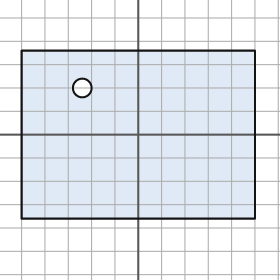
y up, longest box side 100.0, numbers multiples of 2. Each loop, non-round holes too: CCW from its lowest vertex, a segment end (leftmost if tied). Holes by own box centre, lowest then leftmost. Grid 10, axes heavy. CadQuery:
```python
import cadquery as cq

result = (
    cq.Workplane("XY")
    .moveTo(-50.0, -36.0)
    .lineTo(50.0, -36.0)
    .lineTo(50.0, 36.0)
    .lineTo(-50.0, 36.0)
    .close()
    .moveTo(-24.0, 20.0)
    .circle(4.0)
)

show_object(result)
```